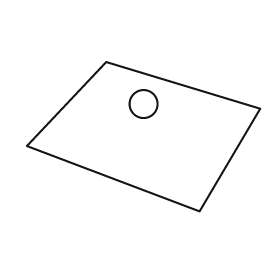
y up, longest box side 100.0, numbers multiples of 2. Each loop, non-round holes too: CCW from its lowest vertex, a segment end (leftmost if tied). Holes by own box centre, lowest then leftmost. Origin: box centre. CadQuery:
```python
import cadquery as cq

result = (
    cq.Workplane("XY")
    .moveTo(24.0, -32.0)
    .lineTo(50.0, 12.0)
    .lineTo(-16.0, 32.0)
    .lineTo(-50.0, -4.0)
    .close()
    .moveTo(0.0, 14.0)
    .circle(6.0)
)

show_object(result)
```